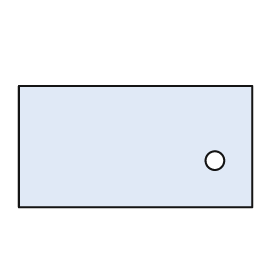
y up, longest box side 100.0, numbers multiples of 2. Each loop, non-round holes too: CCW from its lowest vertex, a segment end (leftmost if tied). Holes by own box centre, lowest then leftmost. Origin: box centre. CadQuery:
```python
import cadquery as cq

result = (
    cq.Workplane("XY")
    .moveTo(-50.0, -26.0)
    .lineTo(50.0, -26.0)
    .lineTo(50.0, 26.0)
    .lineTo(-50.0, 26.0)
    .close()
    .moveTo(34.0, -6.0)
    .circle(4.0)
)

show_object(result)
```